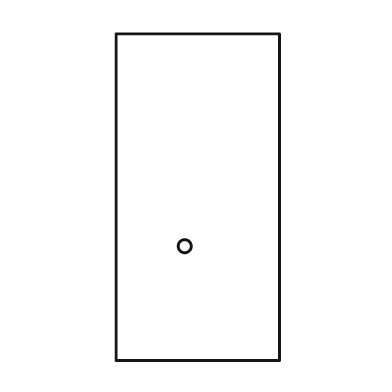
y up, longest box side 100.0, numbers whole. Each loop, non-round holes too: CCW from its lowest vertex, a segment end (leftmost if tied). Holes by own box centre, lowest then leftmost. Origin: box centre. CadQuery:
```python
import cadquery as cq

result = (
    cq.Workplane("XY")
    .moveTo(-25.0, -50.0)
    .lineTo(25.0, -50.0)
    .lineTo(25.0, 50.0)
    .lineTo(-25.0, 50.0)
    .close()
    .moveTo(-4.0, -15.0)
    .circle(2.0)
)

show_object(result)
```